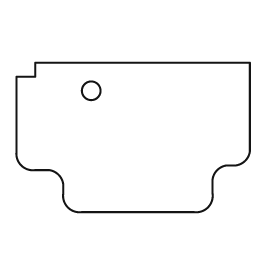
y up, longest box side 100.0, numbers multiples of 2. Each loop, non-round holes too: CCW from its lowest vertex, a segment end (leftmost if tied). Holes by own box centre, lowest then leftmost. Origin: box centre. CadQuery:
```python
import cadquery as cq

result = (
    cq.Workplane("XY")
    .moveTo(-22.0, -32.0)
    .lineTo(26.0, -32.0)
    .threePointArc((32.0, -30.0), (34.0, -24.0))
    .lineTo(34.0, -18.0)
    .threePointArc((36.0, -14.0), (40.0, -12.0))
    .lineTo(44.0, -12.0)
    .threePointArc((48.0, -10.0), (50.0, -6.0))
    .lineTo(50.0, 32.0)
    .lineTo(-42.0, 32.0)
    .lineTo(-42.0, 26.0)
    .lineTo(-50.0, 26.0)
    .lineTo(-50.0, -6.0)
    .threePointArc((-48.0, -12.0), (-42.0, -14.0))
    .lineTo(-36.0, -14.0)
    .threePointArc((-32.0, -16.0), (-30.0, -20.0))
    .lineTo(-30.0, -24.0)
    .threePointArc((-28.0, -30.0), (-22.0, -32.0))
    .close()
    .moveTo(-18.0, 20.0)
    .circle(4.0)
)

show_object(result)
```